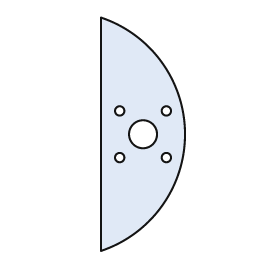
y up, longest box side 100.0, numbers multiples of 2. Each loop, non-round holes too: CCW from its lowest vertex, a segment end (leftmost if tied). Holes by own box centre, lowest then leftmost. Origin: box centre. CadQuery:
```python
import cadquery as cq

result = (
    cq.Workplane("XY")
    .moveTo(-18.0, -50.0)
    .threePointArc((18.0, 0.0), (-18.0, 50.0))
    .close()
    .moveTo(-10.0, -10.0)
    .circle(2.0)
    .moveTo(10.0, -10.0)
    .circle(2.0)
    .moveTo(0.0, 0.0)
    .circle(6.0)
    .moveTo(-10.0, 10.0)
    .circle(2.0)
    .moveTo(10.0, 10.0)
    .circle(2.0)
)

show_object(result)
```